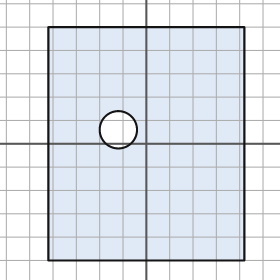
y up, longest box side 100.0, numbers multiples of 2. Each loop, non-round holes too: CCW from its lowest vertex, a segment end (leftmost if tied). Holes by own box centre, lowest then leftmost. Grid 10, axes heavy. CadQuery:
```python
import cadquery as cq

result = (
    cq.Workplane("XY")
    .moveTo(-42.0, -50.0)
    .lineTo(42.0, -50.0)
    .lineTo(42.0, 50.0)
    .lineTo(-42.0, 50.0)
    .close()
    .moveTo(-12.0, 6.0)
    .circle(8.0)
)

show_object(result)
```